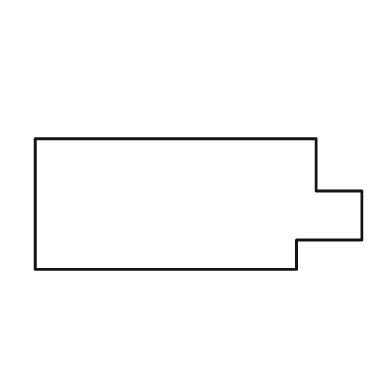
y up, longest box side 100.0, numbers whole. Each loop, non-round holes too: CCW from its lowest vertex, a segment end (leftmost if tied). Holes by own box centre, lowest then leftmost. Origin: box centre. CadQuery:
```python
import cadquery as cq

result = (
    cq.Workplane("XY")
    .moveTo(-50.0, -20.0)
    .lineTo(30.0, -20.0)
    .lineTo(30.0, -11.0)
    .lineTo(50.0, -11.0)
    .lineTo(50.0, 4.0)
    .lineTo(36.0, 4.0)
    .lineTo(36.0, 20.0)
    .lineTo(-50.0, 20.0)
    .close()
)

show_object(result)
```